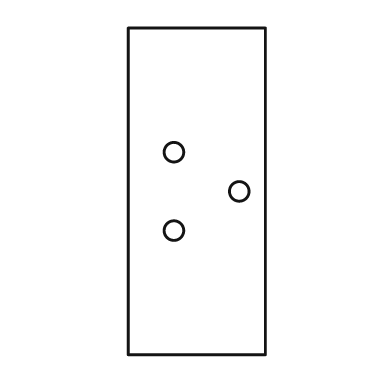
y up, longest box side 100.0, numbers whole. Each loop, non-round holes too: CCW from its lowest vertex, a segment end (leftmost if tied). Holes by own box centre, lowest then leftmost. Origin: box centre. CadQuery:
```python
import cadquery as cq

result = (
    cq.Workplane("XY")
    .moveTo(-21.0, -50.0)
    .lineTo(21.0, -50.0)
    .lineTo(21.0, 50.0)
    .lineTo(-21.0, 50.0)
    .close()
    .moveTo(-7.0, -12.0)
    .circle(3.0)
    .moveTo(13.0, 0.0)
    .circle(3.0)
    .moveTo(-7.0, 12.0)
    .circle(3.0)
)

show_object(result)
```